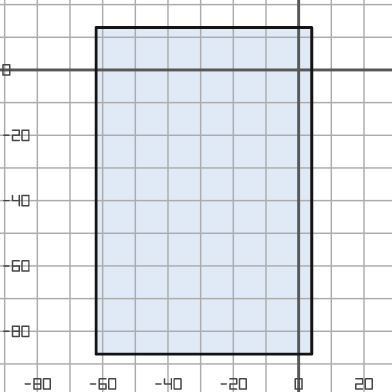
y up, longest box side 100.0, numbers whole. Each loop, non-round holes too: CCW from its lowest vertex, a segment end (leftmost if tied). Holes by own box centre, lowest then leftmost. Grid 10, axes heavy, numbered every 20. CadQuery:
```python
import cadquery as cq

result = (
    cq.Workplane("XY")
    .moveTo(-62.0, -87.0)
    .lineTo(4.0, -87.0)
    .lineTo(4.0, 13.0)
    .lineTo(-62.0, 13.0)
    .close()
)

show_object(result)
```